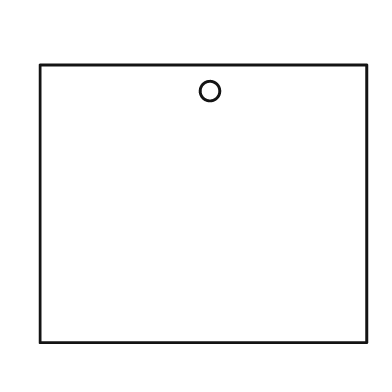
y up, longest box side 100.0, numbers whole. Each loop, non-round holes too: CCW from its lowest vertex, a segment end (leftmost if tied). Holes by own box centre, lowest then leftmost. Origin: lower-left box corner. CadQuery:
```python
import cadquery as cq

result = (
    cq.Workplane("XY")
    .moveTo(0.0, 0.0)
    .lineTo(100.0, 0.0)
    .lineTo(100.0, 85.0)
    .lineTo(0.0, 85.0)
    .close()
    .moveTo(52.0, 77.0)
    .circle(3.0)
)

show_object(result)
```